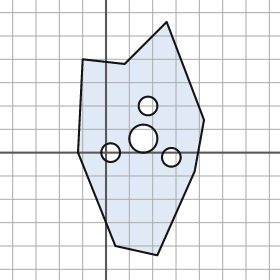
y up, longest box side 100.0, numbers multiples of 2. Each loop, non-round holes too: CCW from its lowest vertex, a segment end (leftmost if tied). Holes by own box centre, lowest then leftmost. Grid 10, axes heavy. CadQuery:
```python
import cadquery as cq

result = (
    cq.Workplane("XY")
    .moveTo(22.0, -44.0)
    .lineTo(38.0, -8.0)
    .lineTo(42.0, 14.0)
    .lineTo(26.0, 56.0)
    .lineTo(8.0, 38.0)
    .lineTo(-10.0, 40.0)
    .lineTo(-12.0, 0.0)
    .lineTo(4.0, -40.0)
    .close()
    .moveTo(28.0, -2.0)
    .circle(4.0)
    .moveTo(2.0, 0.0)
    .circle(4.0)
    .moveTo(16.0, 6.0)
    .circle(6.0)
    .moveTo(18.0, 20.0)
    .circle(4.0)
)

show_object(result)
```